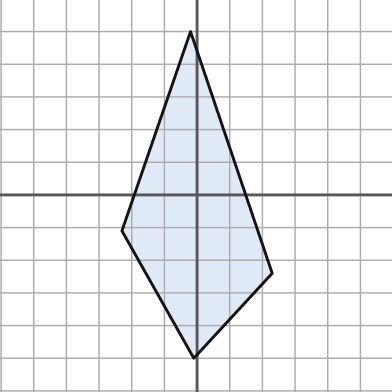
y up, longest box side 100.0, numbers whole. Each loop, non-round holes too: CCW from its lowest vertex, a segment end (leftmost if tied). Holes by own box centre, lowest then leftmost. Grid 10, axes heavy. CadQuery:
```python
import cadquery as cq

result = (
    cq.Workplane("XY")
    .moveTo(-1.0, -50.0)
    .lineTo(23.0, -24.0)
    .lineTo(-2.0, 50.0)
    .lineTo(-23.0, -11.0)
    .close()
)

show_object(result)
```